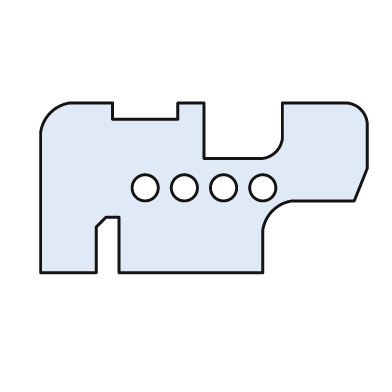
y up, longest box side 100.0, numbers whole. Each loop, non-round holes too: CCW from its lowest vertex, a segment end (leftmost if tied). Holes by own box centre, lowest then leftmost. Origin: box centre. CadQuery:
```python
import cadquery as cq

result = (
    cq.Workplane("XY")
    .moveTo(-50.0, -26.0)
    .lineTo(-33.0, -26.0)
    .lineTo(-33.0, -12.0)
    .lineTo(-30.0, -9.0)
    .lineTo(-26.0, -9.0)
    .lineTo(-26.0, -26.0)
    .lineTo(18.0, -26.0)
    .lineTo(18.0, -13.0)
    .threePointArc((21.0, -7.0), (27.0, -4.0))
    .lineTo(46.0, -4.0)
    .lineTo(50.0, 6.0)
    .lineTo(50.0, 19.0)
    .threePointArc((48.0, 24.0), (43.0, 26.0))
    .lineTo(24.0, 26.0)
    .lineTo(24.0, 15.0)
    .threePointArc((22.0, 11.0), (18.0, 9.0))
    .lineTo(0.0, 9.0)
    .lineTo(0.0, 26.0)
    .lineTo(-8.0, 26.0)
    .lineTo(-8.0, 21.0)
    .lineTo(-28.0, 21.0)
    .lineTo(-28.0, 26.0)
    .lineTo(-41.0, 26.0)
    .threePointArc((-47.0, 23.0), (-50.0, 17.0))
    .close()
    .moveTo(-18.0, 0.0)
    .circle(4.0)
    .moveTo(-6.0, 0.0)
    .circle(4.0)
    .moveTo(6.0, 0.0)
    .circle(4.0)
    .moveTo(18.0, 0.0)
    .circle(4.0)
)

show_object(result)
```